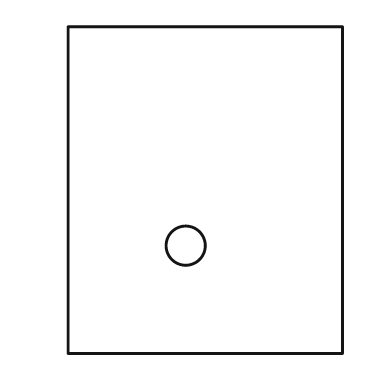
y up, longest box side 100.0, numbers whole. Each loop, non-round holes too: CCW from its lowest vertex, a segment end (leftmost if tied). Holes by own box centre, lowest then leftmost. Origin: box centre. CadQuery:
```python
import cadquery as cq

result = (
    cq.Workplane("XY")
    .moveTo(-42.0, -50.0)
    .lineTo(42.0, -50.0)
    .lineTo(42.0, 50.0)
    .lineTo(-42.0, 50.0)
    .close()
    .moveTo(-6.0, -17.0)
    .circle(6.0)
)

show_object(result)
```